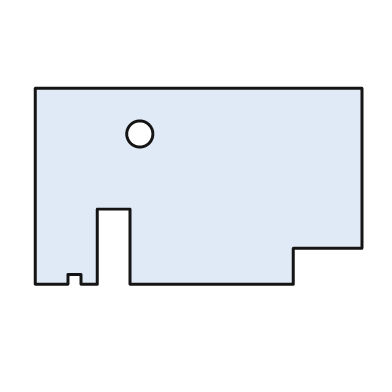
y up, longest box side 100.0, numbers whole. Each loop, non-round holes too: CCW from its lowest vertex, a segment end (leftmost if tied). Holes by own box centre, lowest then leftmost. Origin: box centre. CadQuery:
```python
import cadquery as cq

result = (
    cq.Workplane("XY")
    .moveTo(-50.0, -30.0)
    .lineTo(-40.0, -30.0)
    .lineTo(-40.0, -27.0)
    .lineTo(-36.0, -27.0)
    .lineTo(-36.0, -30.0)
    .lineTo(-31.0, -30.0)
    .lineTo(-31.0, -7.0)
    .lineTo(-21.0, -7.0)
    .lineTo(-21.0, -30.0)
    .lineTo(29.0, -30.0)
    .lineTo(29.0, -19.0)
    .lineTo(50.0, -19.0)
    .lineTo(50.0, 30.0)
    .lineTo(-50.0, 30.0)
    .close()
    .moveTo(-18.0, 16.0)
    .circle(4.0)
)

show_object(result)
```